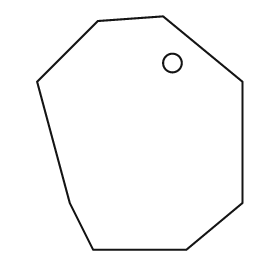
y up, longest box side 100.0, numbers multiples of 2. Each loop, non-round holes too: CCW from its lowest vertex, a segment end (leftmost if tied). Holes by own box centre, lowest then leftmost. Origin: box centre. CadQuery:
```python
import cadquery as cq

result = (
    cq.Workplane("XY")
    .moveTo(-20.0, -50.0)
    .lineTo(20.0, -50.0)
    .lineTo(44.0, -30.0)
    .lineTo(44.0, 22.0)
    .lineTo(10.0, 50.0)
    .lineTo(-18.0, 48.0)
    .lineTo(-44.0, 22.0)
    .lineTo(-30.0, -30.0)
    .close()
    .moveTo(14.0, 30.0)
    .circle(4.0)
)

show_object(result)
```